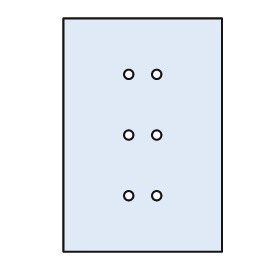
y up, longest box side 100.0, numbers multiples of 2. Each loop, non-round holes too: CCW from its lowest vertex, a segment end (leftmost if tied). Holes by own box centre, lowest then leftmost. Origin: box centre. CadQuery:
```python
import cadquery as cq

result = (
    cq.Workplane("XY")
    .moveTo(-34.0, -50.0)
    .lineTo(34.0, -50.0)
    .lineTo(34.0, 50.0)
    .lineTo(-34.0, 50.0)
    .close()
    .moveTo(-6.0, -26.0)
    .circle(2.0)
    .moveTo(6.0, -26.0)
    .circle(2.0)
    .moveTo(-6.0, 0.0)
    .circle(2.0)
    .moveTo(6.0, 0.0)
    .circle(2.0)
    .moveTo(-6.0, 26.0)
    .circle(2.0)
    .moveTo(6.0, 26.0)
    .circle(2.0)
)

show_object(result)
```